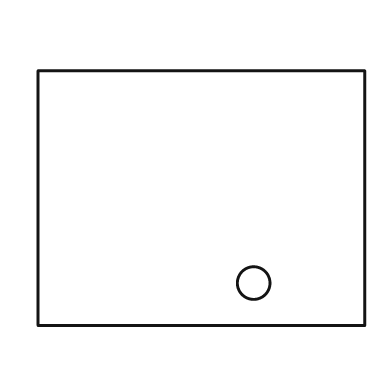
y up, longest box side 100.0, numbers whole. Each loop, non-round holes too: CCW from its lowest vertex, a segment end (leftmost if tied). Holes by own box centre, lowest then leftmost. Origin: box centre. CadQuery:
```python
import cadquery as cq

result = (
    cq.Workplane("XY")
    .moveTo(-50.0, -39.0)
    .lineTo(50.0, -39.0)
    .lineTo(50.0, 39.0)
    .lineTo(-50.0, 39.0)
    .close()
    .moveTo(16.0, -26.0)
    .circle(5.0)
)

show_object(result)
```